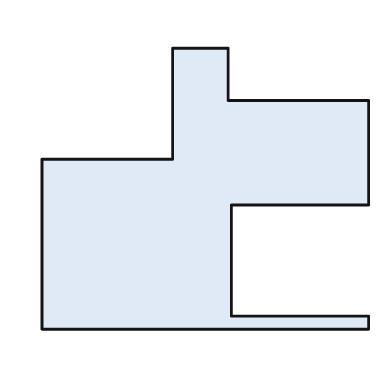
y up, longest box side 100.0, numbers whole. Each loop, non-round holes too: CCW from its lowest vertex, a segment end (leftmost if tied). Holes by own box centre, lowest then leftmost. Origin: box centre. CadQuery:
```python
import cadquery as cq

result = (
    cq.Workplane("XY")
    .moveTo(-50.0, -43.0)
    .lineTo(50.0, -43.0)
    .lineTo(50.0, -39.0)
    .lineTo(8.0, -39.0)
    .lineTo(8.0, -5.0)
    .lineTo(50.0, -5.0)
    .lineTo(50.0, 27.0)
    .lineTo(7.0, 27.0)
    .lineTo(7.0, 43.0)
    .lineTo(-10.0, 43.0)
    .lineTo(-10.0, 9.0)
    .lineTo(-50.0, 9.0)
    .close()
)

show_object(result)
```